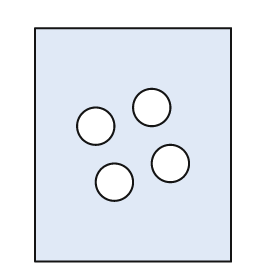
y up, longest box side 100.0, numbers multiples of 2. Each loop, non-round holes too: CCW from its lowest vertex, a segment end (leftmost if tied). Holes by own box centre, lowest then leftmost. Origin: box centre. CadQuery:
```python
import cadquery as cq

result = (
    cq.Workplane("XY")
    .moveTo(-42.0, -50.0)
    .lineTo(42.0, -50.0)
    .lineTo(42.0, 50.0)
    .lineTo(-42.0, 50.0)
    .close()
    .moveTo(-8.0, -16.0)
    .circle(8.0)
    .moveTo(16.0, -8.0)
    .circle(8.0)
    .moveTo(-16.0, 8.0)
    .circle(8.0)
    .moveTo(8.0, 16.0)
    .circle(8.0)
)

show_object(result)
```